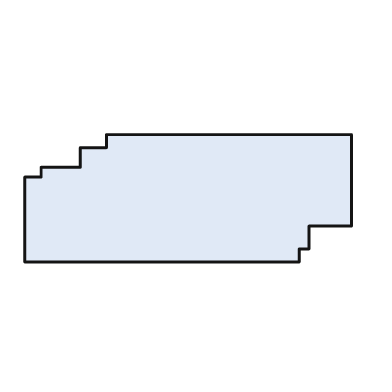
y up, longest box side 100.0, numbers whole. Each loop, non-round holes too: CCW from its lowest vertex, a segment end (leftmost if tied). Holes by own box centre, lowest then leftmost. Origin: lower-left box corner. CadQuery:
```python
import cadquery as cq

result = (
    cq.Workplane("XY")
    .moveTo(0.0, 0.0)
    .lineTo(84.0, 0.0)
    .lineTo(84.0, 4.0)
    .lineTo(87.0, 4.0)
    .lineTo(87.0, 11.0)
    .lineTo(100.0, 11.0)
    .lineTo(100.0, 39.0)
    .lineTo(25.0, 39.0)
    .lineTo(25.0, 35.0)
    .lineTo(17.0, 35.0)
    .lineTo(17.0, 29.0)
    .lineTo(5.0, 29.0)
    .lineTo(5.0, 26.0)
    .lineTo(0.0, 26.0)
    .close()
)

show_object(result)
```